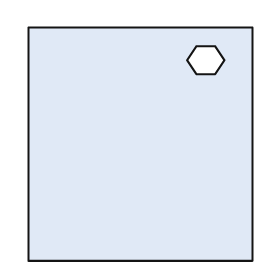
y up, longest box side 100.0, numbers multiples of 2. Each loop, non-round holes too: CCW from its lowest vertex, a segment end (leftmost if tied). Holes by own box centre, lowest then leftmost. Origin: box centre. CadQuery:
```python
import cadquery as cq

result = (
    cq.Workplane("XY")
    .moveTo(-48.0, -50.0)
    .lineTo(48.0, -50.0)
    .lineTo(48.0, 50.0)
    .lineTo(-48.0, 50.0)
    .close()
    .moveTo(24.0, 30.0)
    .lineTo(32.0, 30.0)
    .lineTo(36.0, 36.0)
    .lineTo(32.0, 42.0)
    .lineTo(24.0, 42.0)
    .lineTo(20.0, 36.0)
    .close()
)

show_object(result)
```